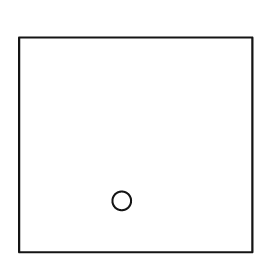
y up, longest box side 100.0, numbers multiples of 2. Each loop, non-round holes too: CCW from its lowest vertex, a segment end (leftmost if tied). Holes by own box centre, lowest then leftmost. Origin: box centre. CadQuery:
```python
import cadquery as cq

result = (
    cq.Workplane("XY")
    .moveTo(-50.0, -46.0)
    .lineTo(50.0, -46.0)
    .lineTo(50.0, 46.0)
    .lineTo(-50.0, 46.0)
    .close()
    .moveTo(-6.0, -24.0)
    .circle(4.0)
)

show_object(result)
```